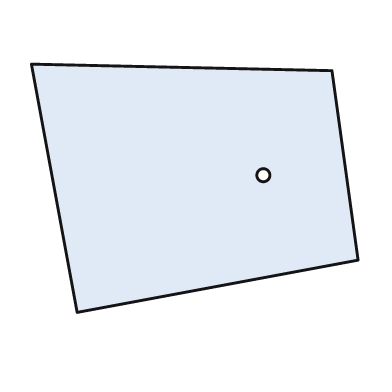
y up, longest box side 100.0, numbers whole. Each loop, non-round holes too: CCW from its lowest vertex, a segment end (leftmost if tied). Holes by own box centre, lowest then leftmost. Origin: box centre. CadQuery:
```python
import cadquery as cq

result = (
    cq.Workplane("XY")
    .moveTo(-36.0, -38.0)
    .lineTo(50.0, -22.0)
    .lineTo(42.0, 36.0)
    .lineTo(-50.0, 38.0)
    .close()
    .moveTo(21.0, 4.0)
    .circle(2.0)
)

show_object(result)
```